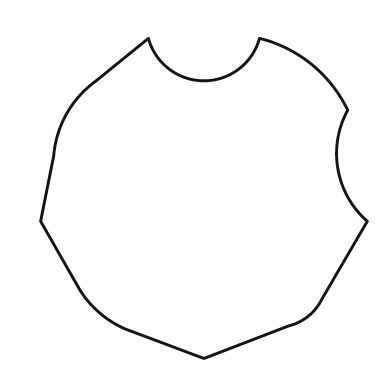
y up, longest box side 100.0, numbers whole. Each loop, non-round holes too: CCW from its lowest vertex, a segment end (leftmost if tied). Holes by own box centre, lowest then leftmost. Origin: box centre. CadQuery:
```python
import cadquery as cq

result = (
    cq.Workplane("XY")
    .moveTo(0.0, -49.0)
    .lineTo(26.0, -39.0)
    .threePointArc((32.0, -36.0), (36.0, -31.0))
    .lineTo(50.0, -7.0)
    .threePointArc((41.0, 9.0), (44.0, 27.0))
    .threePointArc((33.0, 41.0), (17.0, 49.0))
    .threePointArc((0.0, 36.0), (-17.0, 49.0))
    .lineTo(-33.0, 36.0)
    .threePointArc((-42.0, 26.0), (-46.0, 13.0))
    .lineTo(-50.0, -7.0)
    .lineTo(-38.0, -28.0)
    .threePointArc((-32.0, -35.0), (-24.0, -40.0))
    .close()
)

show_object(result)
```